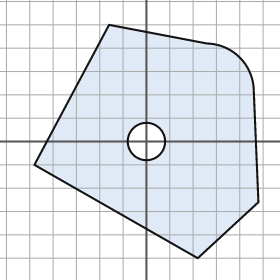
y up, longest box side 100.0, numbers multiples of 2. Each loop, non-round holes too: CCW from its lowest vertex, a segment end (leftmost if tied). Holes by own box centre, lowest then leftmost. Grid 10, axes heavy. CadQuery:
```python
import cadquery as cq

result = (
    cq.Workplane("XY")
    .moveTo(22.0, -50.0)
    .lineTo(48.0, -26.0)
    .lineTo(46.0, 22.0)
    .threePointArc((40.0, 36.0), (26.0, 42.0))
    .lineTo(-16.0, 50.0)
    .lineTo(-48.0, -10.0)
    .close()
    .moveTo(0.0, 0.0)
    .circle(8.0)
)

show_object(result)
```